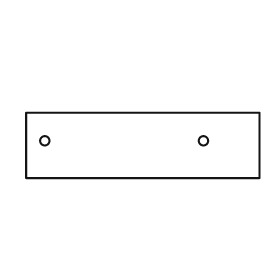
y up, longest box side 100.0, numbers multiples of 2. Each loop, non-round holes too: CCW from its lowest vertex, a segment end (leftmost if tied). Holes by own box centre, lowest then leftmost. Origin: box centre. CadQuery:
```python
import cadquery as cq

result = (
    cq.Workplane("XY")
    .moveTo(-50.0, -14.0)
    .lineTo(50.0, -14.0)
    .lineTo(50.0, 14.0)
    .lineTo(-50.0, 14.0)
    .close()
    .moveTo(-42.0, 2.0)
    .circle(2.0)
    .moveTo(26.0, 2.0)
    .circle(2.0)
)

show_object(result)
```